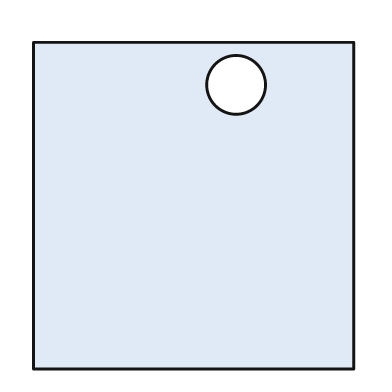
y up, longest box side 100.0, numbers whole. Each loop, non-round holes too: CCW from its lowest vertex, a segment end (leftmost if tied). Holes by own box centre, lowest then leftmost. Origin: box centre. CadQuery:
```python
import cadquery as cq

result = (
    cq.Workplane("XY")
    .moveTo(-49.0, -50.0)
    .lineTo(49.0, -50.0)
    .lineTo(49.0, 50.0)
    .lineTo(-49.0, 50.0)
    .close()
    .moveTo(13.0, 37.0)
    .circle(9.0)
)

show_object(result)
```